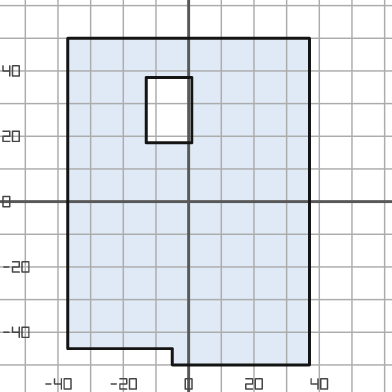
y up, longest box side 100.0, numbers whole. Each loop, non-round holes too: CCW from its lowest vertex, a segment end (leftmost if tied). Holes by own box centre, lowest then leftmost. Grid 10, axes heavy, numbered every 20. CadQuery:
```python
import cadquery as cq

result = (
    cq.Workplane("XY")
    .moveTo(-5.0, -50.0)
    .lineTo(37.0, -50.0)
    .lineTo(37.0, 50.0)
    .lineTo(-37.0, 50.0)
    .lineTo(-37.0, -45.0)
    .lineTo(-5.0, -45.0)
    .close()
    .moveTo(-13.0, 18.0)
    .lineTo(1.0, 18.0)
    .lineTo(1.0, 38.0)
    .lineTo(-13.0, 38.0)
    .close()
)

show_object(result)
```